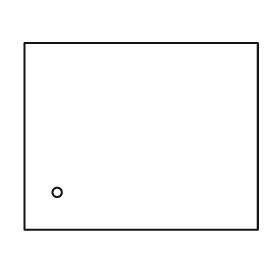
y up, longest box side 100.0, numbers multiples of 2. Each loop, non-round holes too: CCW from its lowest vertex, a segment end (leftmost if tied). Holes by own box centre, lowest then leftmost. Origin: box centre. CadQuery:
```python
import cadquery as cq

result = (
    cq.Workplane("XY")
    .moveTo(-50.0, -40.0)
    .lineTo(50.0, -40.0)
    .lineTo(50.0, 40.0)
    .lineTo(-50.0, 40.0)
    .close()
    .moveTo(-36.0, -24.0)
    .circle(2.0)
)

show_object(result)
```